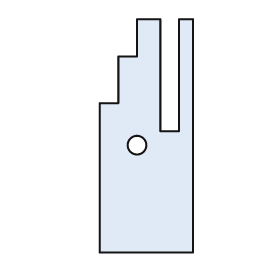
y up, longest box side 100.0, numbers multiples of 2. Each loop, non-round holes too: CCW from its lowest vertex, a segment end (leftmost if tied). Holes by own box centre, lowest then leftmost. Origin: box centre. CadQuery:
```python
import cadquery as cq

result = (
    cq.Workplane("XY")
    .moveTo(-20.0, -50.0)
    .lineTo(20.0, -50.0)
    .lineTo(20.0, 50.0)
    .lineTo(14.0, 50.0)
    .lineTo(14.0, 2.0)
    .lineTo(6.0, 2.0)
    .lineTo(6.0, 50.0)
    .lineTo(-4.0, 50.0)
    .lineTo(-4.0, 34.0)
    .lineTo(-12.0, 34.0)
    .lineTo(-12.0, 14.0)
    .lineTo(-20.0, 14.0)
    .close()
    .moveTo(-4.0, -4.0)
    .circle(4.0)
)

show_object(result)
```